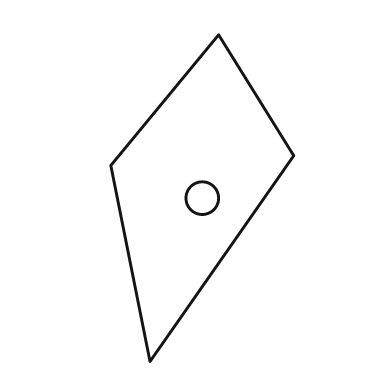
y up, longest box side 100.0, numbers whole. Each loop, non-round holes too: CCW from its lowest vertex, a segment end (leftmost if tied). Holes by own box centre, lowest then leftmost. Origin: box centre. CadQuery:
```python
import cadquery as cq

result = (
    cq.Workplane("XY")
    .moveTo(-16.0, -50.0)
    .lineTo(28.0, 13.0)
    .lineTo(5.0, 50.0)
    .lineTo(-28.0, 10.0)
    .close()
    .moveTo(0.0, 0.0)
    .circle(5.0)
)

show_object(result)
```